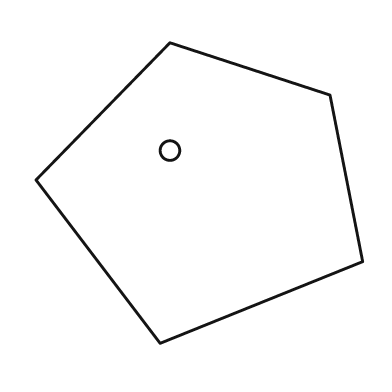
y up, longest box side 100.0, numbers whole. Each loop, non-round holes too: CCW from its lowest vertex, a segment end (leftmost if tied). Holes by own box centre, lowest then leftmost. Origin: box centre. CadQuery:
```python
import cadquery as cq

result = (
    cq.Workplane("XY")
    .moveTo(-12.0, -46.0)
    .lineTo(50.0, -21.0)
    .lineTo(40.0, 30.0)
    .lineTo(-9.0, 46.0)
    .lineTo(-50.0, 4.0)
    .close()
    .moveTo(-9.0, 13.0)
    .circle(3.0)
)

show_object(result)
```